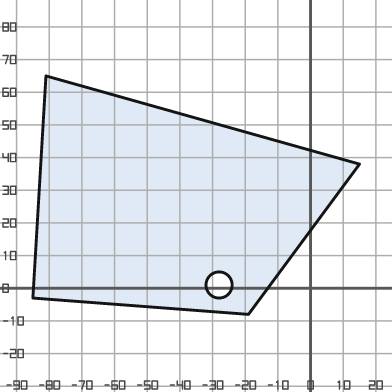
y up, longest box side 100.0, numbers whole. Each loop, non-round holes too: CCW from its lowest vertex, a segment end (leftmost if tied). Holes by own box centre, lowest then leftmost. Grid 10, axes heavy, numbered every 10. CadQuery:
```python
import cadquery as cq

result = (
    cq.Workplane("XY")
    .moveTo(-19.0, -8.0)
    .lineTo(15.0, 38.0)
    .lineTo(-81.0, 65.0)
    .lineTo(-85.0, -3.0)
    .close()
    .moveTo(-28.0, 1.0)
    .circle(4.0)
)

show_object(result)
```